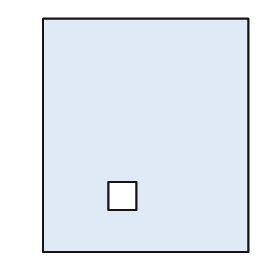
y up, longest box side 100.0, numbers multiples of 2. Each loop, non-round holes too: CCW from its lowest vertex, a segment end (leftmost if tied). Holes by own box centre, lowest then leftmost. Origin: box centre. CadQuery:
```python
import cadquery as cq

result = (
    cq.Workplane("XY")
    .moveTo(-44.0, -50.0)
    .lineTo(44.0, -50.0)
    .lineTo(44.0, 50.0)
    .lineTo(-44.0, 50.0)
    .close()
    .moveTo(-16.0, -32.0)
    .lineTo(-4.0, -32.0)
    .lineTo(-4.0, -20.0)
    .lineTo(-16.0, -20.0)
    .close()
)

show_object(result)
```